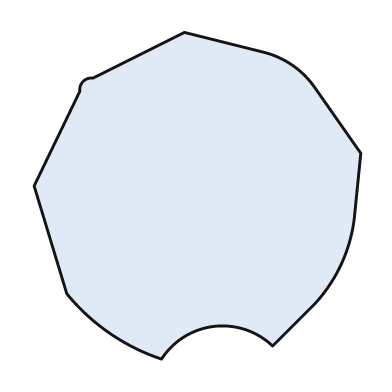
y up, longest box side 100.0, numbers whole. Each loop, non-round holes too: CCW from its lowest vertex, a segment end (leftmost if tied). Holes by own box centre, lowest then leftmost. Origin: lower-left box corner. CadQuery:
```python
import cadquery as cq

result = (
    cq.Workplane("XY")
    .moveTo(39.0, 0.0)
    .threePointArc((55.0, 10.0), (73.0, 4.0))
    .lineTo(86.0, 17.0)
    .threePointArc((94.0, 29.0), (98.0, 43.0))
    .lineTo(100.0, 63.0)
    .lineTo(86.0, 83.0)
    .threePointArc((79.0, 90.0), (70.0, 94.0))
    .lineTo(46.0, 100.0)
    .lineTo(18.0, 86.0)
    .threePointArc((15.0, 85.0), (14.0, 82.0))
    .lineTo(0.0, 53.0)
    .lineTo(10.0, 20.0)
    .threePointArc((23.0, 8.0), (39.0, 0.0))
    .close()
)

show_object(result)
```